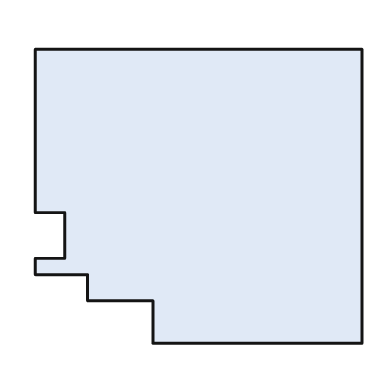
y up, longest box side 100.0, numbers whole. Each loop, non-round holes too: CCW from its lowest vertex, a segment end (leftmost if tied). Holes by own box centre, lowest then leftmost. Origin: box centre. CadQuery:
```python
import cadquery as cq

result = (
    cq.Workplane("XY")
    .moveTo(-14.0, -45.0)
    .lineTo(50.0, -45.0)
    .lineTo(50.0, 45.0)
    .lineTo(-50.0, 45.0)
    .lineTo(-50.0, -5.0)
    .lineTo(-41.0, -5.0)
    .lineTo(-41.0, -19.0)
    .lineTo(-50.0, -19.0)
    .lineTo(-50.0, -24.0)
    .lineTo(-34.0, -24.0)
    .lineTo(-34.0, -32.0)
    .lineTo(-14.0, -32.0)
    .close()
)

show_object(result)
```